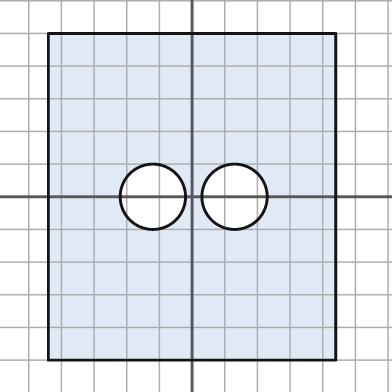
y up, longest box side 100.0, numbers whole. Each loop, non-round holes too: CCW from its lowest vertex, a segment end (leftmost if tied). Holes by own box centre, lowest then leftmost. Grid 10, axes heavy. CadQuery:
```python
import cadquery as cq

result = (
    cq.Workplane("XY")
    .moveTo(-44.0, -50.0)
    .lineTo(44.0, -50.0)
    .lineTo(44.0, 50.0)
    .lineTo(-44.0, 50.0)
    .close()
    .moveTo(-12.0, 0.0)
    .circle(10.0)
    .moveTo(13.0, 0.0)
    .circle(10.0)
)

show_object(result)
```